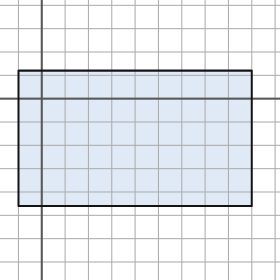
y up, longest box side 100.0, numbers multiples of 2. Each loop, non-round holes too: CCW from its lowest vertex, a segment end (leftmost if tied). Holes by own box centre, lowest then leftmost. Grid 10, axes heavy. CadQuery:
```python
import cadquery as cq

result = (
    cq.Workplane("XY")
    .moveTo(-10.0, -46.0)
    .lineTo(90.0, -46.0)
    .lineTo(90.0, 12.0)
    .lineTo(-10.0, 12.0)
    .close()
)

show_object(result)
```